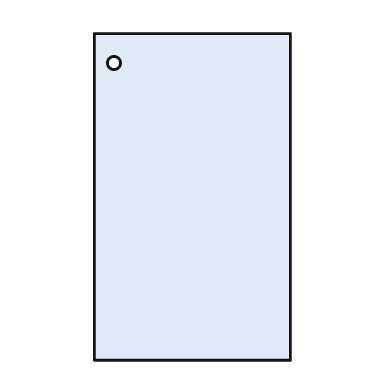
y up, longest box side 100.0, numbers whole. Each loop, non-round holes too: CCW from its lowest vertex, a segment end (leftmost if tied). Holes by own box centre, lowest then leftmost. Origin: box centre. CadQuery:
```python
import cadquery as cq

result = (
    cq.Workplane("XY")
    .moveTo(-30.0, -50.0)
    .lineTo(30.0, -50.0)
    .lineTo(30.0, 50.0)
    .lineTo(-30.0, 50.0)
    .close()
    .moveTo(-24.0, 41.0)
    .circle(2.0)
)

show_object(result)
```